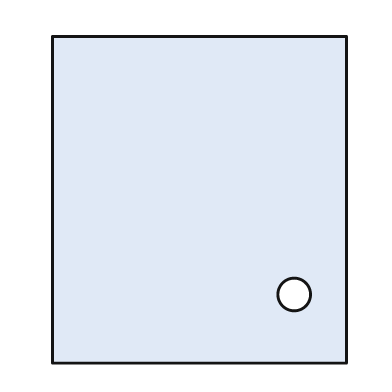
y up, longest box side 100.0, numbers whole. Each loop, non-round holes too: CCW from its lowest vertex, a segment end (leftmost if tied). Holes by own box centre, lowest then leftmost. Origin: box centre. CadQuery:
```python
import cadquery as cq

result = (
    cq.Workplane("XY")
    .moveTo(-45.0, -50.0)
    .lineTo(45.0, -50.0)
    .lineTo(45.0, 50.0)
    .lineTo(-45.0, 50.0)
    .close()
    .moveTo(29.0, -29.0)
    .circle(5.0)
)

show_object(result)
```